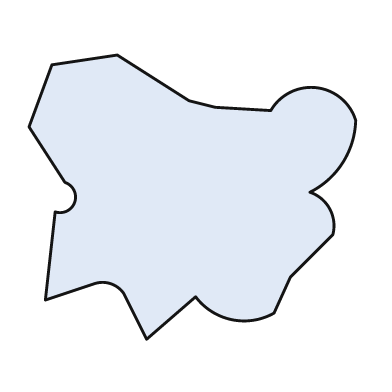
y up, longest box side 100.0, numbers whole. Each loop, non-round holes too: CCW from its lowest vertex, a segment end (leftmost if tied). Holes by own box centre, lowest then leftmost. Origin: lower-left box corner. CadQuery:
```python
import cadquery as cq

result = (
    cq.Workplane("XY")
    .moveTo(36.0, 0.0)
    .lineTo(51.0, 13.0)
    .threePointArc((62.0, 6.0), (75.0, 8.0))
    .lineTo(80.0, 19.0)
    .lineTo(93.0, 32.0)
    .threePointArc((92.0, 40.0), (86.0, 45.0))
    .threePointArc((96.0, 54.0), (100.0, 67.0))
    .threePointArc((88.0, 77.0), (74.0, 70.0))
    .lineTo(57.0, 71.0)
    .lineTo(49.0, 73.0)
    .lineTo(27.0, 87.0)
    .lineTo(7.0, 84.0)
    .lineTo(0.0, 65.0)
    .lineTo(11.0, 48.0)
    .threePointArc((14.0, 42.0), (8.0, 39.0))
    .lineTo(5.0, 12.0)
    .lineTo(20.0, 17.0)
    .threePointArc((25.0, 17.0), (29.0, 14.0))
    .close()
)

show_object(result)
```